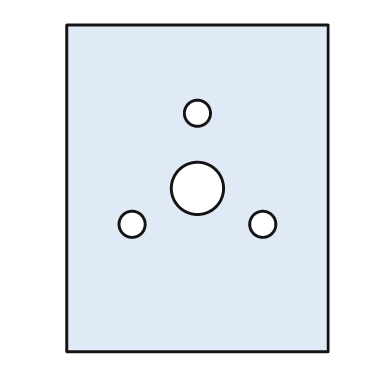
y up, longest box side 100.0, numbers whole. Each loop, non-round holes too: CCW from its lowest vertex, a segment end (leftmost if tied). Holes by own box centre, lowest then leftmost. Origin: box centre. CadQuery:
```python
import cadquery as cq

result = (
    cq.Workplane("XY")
    .moveTo(-40.0, -50.0)
    .lineTo(40.0, -50.0)
    .lineTo(40.0, 50.0)
    .lineTo(-40.0, 50.0)
    .close()
    .moveTo(-20.0, -11.0)
    .circle(4.0)
    .moveTo(20.0, -11.0)
    .circle(4.0)
    .moveTo(0.0, 0.0)
    .circle(8.0)
    .moveTo(0.0, 23.0)
    .circle(4.0)
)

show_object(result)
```